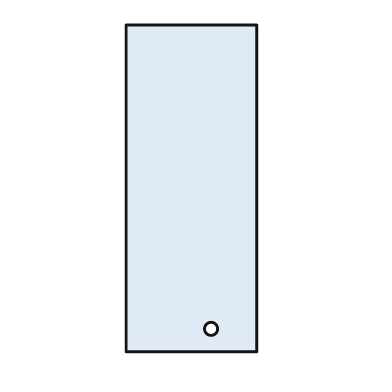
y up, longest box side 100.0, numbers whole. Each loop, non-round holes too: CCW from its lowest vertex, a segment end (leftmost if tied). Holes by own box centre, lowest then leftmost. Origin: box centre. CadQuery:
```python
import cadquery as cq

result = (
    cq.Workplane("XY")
    .moveTo(-20.0, -50.0)
    .lineTo(20.0, -50.0)
    .lineTo(20.0, 50.0)
    .lineTo(-20.0, 50.0)
    .close()
    .moveTo(6.0, -43.0)
    .circle(2.0)
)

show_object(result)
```